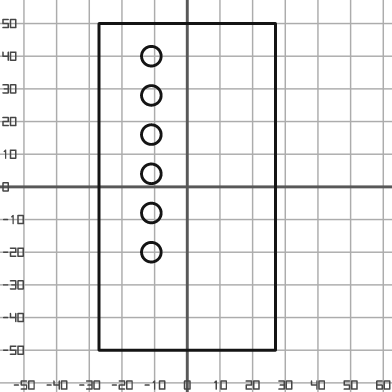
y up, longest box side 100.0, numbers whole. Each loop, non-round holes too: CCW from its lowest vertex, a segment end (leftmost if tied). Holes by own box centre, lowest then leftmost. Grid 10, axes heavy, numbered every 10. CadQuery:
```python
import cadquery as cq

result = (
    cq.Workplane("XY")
    .moveTo(-27.0, -50.0)
    .lineTo(27.0, -50.0)
    .lineTo(27.0, 50.0)
    .lineTo(-27.0, 50.0)
    .close()
    .moveTo(-11.0, -20.0)
    .circle(3.0)
    .moveTo(-11.0, -8.0)
    .circle(3.0)
    .moveTo(-11.0, 4.0)
    .circle(3.0)
    .moveTo(-11.0, 16.0)
    .circle(3.0)
    .moveTo(-11.0, 28.0)
    .circle(3.0)
    .moveTo(-11.0, 40.0)
    .circle(3.0)
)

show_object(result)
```